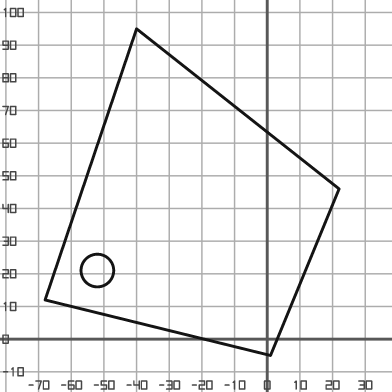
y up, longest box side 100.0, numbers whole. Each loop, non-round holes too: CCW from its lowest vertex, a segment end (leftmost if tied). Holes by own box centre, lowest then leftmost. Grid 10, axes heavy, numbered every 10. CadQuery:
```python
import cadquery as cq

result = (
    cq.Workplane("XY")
    .moveTo(1.0, -5.0)
    .lineTo(22.0, 46.0)
    .lineTo(-40.0, 95.0)
    .lineTo(-68.0, 12.0)
    .close()
    .moveTo(-52.0, 21.0)
    .circle(5.0)
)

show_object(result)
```